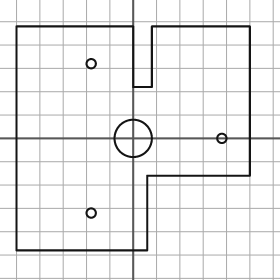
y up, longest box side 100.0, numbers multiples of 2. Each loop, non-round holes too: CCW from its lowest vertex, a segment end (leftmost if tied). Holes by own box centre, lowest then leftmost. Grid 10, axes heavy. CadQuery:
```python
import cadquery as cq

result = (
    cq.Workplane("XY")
    .moveTo(-50.0, -48.0)
    .lineTo(6.0, -48.0)
    .lineTo(6.0, -16.0)
    .lineTo(50.0, -16.0)
    .lineTo(50.0, 48.0)
    .lineTo(8.0, 48.0)
    .lineTo(8.0, 22.0)
    .lineTo(0.0, 22.0)
    .lineTo(0.0, 48.0)
    .lineTo(-50.0, 48.0)
    .close()
    .moveTo(-18.0, -32.0)
    .circle(2.0)
    .moveTo(0.0, 0.0)
    .circle(8.0)
    .moveTo(38.0, 0.0)
    .circle(2.0)
    .moveTo(-18.0, 32.0)
    .circle(2.0)
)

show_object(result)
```